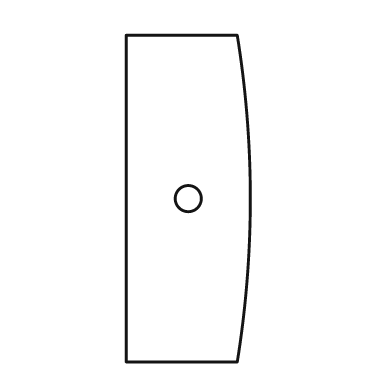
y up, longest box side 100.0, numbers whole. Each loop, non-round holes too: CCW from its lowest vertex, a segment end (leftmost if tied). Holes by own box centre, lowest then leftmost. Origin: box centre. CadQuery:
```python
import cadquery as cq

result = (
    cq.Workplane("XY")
    .moveTo(-19.0, -50.0)
    .lineTo(15.0, -50.0)
    .threePointArc((19.0, 0.0), (15.0, 50.0))
    .lineTo(-19.0, 50.0)
    .close()
    .moveTo(0.0, 0.0)
    .circle(4.0)
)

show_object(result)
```